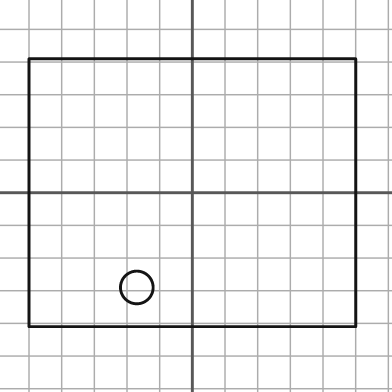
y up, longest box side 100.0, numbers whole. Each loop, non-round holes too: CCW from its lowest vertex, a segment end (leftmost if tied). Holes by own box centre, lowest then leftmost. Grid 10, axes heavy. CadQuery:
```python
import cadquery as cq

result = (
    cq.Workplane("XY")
    .moveTo(-50.0, -41.0)
    .lineTo(50.0, -41.0)
    .lineTo(50.0, 41.0)
    .lineTo(-50.0, 41.0)
    .close()
    .moveTo(-17.0, -29.0)
    .circle(5.0)
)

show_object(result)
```